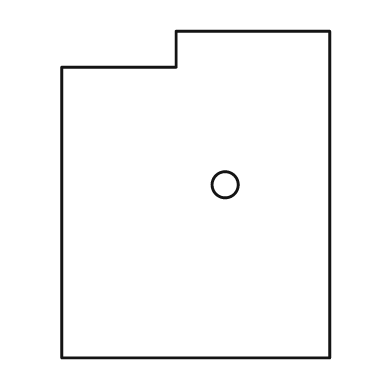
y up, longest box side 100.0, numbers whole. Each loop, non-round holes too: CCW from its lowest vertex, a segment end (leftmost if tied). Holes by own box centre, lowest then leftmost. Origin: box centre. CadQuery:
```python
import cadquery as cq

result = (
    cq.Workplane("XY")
    .moveTo(-41.0, -50.0)
    .lineTo(41.0, -50.0)
    .lineTo(41.0, 50.0)
    .lineTo(-6.0, 50.0)
    .lineTo(-6.0, 39.0)
    .lineTo(-41.0, 39.0)
    .close()
    .moveTo(9.0, 3.0)
    .circle(4.0)
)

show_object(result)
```